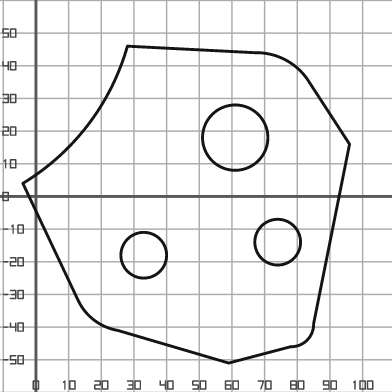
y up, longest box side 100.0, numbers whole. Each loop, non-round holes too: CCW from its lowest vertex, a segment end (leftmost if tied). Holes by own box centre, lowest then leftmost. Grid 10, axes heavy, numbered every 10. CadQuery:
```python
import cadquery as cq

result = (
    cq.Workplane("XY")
    .moveTo(59.0, -51.0)
    .lineTo(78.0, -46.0)
    .threePointArc((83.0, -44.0), (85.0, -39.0))
    .lineTo(96.0, 16.0)
    .lineTo(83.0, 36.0)
    .threePointArc((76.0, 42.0), (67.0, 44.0))
    .lineTo(28.0, 46.0)
    .threePointArc((16.0, 22.0), (-4.0, 4.0))
    .lineTo(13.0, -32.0)
    .threePointArc((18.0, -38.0), (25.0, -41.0))
    .close()
    .moveTo(33.0, -18.0)
    .circle(7.0)
    .moveTo(74.0, -14.0)
    .circle(7.0)
    .moveTo(61.0, 18.0)
    .circle(10.0)
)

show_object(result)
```